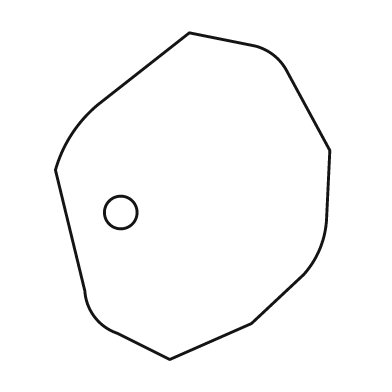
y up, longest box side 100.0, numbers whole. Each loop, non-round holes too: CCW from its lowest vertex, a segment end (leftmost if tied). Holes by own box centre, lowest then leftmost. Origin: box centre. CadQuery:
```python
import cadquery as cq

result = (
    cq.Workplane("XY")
    .moveTo(-7.0, -50.0)
    .lineTo(18.0, -39.0)
    .lineTo(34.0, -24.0)
    .threePointArc((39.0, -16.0), (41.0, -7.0))
    .lineTo(42.0, 14.0)
    .lineTo(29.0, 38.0)
    .threePointArc((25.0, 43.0), (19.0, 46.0))
    .lineTo(-1.0, 50.0)
    .lineTo(-29.0, 28.0)
    .threePointArc((-37.0, 19.0), (-42.0, 8.0))
    .lineTo(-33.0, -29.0)
    .threePointArc((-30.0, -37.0), (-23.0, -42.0))
    .close()
    .moveTo(-22.0, -5.0)
    .circle(5.0)
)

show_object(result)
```